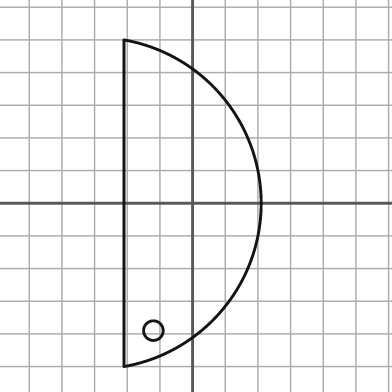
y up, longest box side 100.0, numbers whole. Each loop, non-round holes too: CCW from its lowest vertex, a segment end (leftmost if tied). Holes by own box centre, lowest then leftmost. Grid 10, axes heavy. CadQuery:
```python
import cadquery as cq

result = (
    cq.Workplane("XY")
    .moveTo(-21.0, -50.0)
    .threePointArc((21.0, 0.0), (-21.0, 50.0))
    .close()
    .moveTo(-12.0, -39.0)
    .circle(3.0)
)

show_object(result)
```